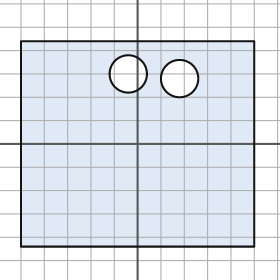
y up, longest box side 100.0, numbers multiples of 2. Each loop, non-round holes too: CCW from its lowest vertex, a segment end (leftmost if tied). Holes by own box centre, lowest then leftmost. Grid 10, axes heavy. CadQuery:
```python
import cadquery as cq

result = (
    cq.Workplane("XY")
    .moveTo(-50.0, -44.0)
    .lineTo(50.0, -44.0)
    .lineTo(50.0, 44.0)
    .lineTo(-50.0, 44.0)
    .close()
    .moveTo(18.0, 28.0)
    .circle(8.0)
    .moveTo(-4.0, 30.0)
    .circle(8.0)
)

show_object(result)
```